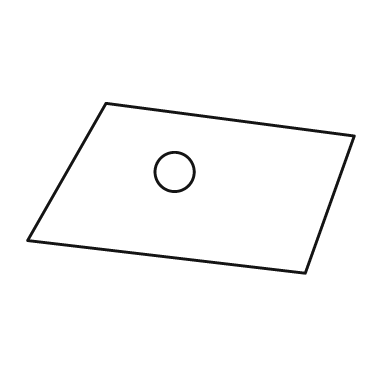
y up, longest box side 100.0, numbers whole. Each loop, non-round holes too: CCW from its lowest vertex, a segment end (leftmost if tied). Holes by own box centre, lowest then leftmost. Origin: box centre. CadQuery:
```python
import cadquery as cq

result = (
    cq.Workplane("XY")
    .moveTo(35.0, -26.0)
    .lineTo(50.0, 16.0)
    .lineTo(-26.0, 26.0)
    .lineTo(-50.0, -16.0)
    .close()
    .moveTo(-5.0, 5.0)
    .circle(6.0)
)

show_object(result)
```